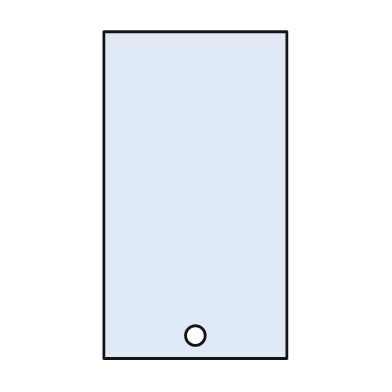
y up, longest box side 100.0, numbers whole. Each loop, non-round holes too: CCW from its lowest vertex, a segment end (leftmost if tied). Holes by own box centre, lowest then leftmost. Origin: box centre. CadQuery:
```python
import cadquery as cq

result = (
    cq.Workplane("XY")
    .moveTo(-28.0, -50.0)
    .lineTo(28.0, -50.0)
    .lineTo(28.0, 50.0)
    .lineTo(-28.0, 50.0)
    .close()
    .moveTo(0.0, -43.0)
    .circle(3.0)
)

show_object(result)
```